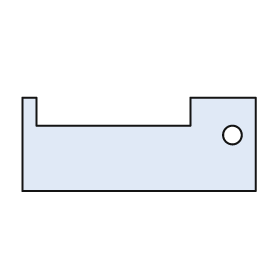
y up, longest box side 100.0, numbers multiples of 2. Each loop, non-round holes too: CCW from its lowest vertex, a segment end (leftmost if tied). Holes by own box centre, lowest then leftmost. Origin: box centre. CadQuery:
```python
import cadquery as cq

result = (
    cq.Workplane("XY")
    .moveTo(-50.0, -20.0)
    .lineTo(50.0, -20.0)
    .lineTo(50.0, 20.0)
    .lineTo(22.0, 20.0)
    .lineTo(22.0, 8.0)
    .lineTo(-44.0, 8.0)
    .lineTo(-44.0, 20.0)
    .lineTo(-50.0, 20.0)
    .close()
    .moveTo(40.0, 4.0)
    .circle(4.0)
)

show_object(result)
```